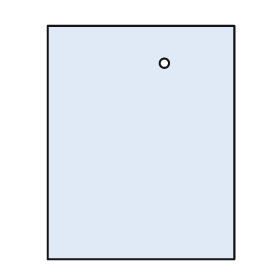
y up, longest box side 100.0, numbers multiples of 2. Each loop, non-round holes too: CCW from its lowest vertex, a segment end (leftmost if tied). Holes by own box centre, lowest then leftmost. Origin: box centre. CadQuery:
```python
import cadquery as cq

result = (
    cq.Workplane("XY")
    .moveTo(-40.0, -50.0)
    .lineTo(40.0, -50.0)
    .lineTo(40.0, 50.0)
    .lineTo(-40.0, 50.0)
    .close()
    .moveTo(10.0, 34.0)
    .circle(2.0)
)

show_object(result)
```